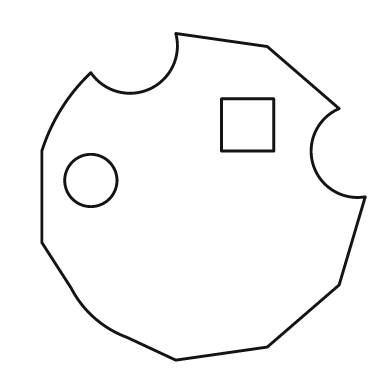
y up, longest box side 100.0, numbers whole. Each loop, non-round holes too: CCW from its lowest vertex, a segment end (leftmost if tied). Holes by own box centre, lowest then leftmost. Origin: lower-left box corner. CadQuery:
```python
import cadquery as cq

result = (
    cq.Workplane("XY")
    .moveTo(41.0, 0.0)
    .lineTo(69.0, 4.0)
    .lineTo(91.0, 23.0)
    .lineTo(99.0, 50.0)
    .threePointArc((83.0, 60.0), (91.0, 77.0))
    .lineTo(69.0, 96.0)
    .lineTo(41.0, 100.0)
    .threePointArc((33.0, 83.0), (15.0, 88.0))
    .threePointArc((6.0, 77.0), (0.0, 64.0))
    .lineTo(0.0, 36.0)
    .lineTo(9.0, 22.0)
    .threePointArc((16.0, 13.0), (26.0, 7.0))
    .close()
    .moveTo(15.0, 55.0)
    .circle(8.0)
    .moveTo(55.0, 64.0)
    .lineTo(71.0, 64.0)
    .lineTo(71.0, 80.0)
    .lineTo(55.0, 80.0)
    .close()
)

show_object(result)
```